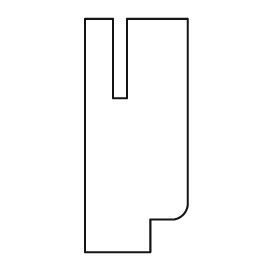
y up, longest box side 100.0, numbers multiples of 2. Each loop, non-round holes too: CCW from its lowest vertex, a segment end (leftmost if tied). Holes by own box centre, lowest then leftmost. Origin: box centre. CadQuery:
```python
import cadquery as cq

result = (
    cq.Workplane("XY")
    .moveTo(-22.0, -50.0)
    .lineTo(6.0, -50.0)
    .lineTo(6.0, -36.0)
    .lineTo(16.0, -36.0)
    .threePointArc((20.0, -34.0), (22.0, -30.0))
    .lineTo(22.0, 50.0)
    .lineTo(-4.0, 50.0)
    .lineTo(-4.0, 16.0)
    .lineTo(-10.0, 16.0)
    .lineTo(-10.0, 50.0)
    .lineTo(-22.0, 50.0)
    .close()
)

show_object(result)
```